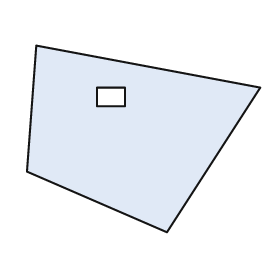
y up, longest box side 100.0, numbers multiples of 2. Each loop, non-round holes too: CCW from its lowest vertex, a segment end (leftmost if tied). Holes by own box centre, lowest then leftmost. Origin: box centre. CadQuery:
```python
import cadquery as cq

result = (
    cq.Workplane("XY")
    .moveTo(10.0, -40.0)
    .lineTo(50.0, 22.0)
    .lineTo(-46.0, 40.0)
    .lineTo(-50.0, -14.0)
    .close()
    .moveTo(-20.0, 14.0)
    .lineTo(-8.0, 14.0)
    .lineTo(-8.0, 22.0)
    .lineTo(-20.0, 22.0)
    .close()
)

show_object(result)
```